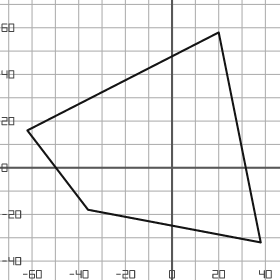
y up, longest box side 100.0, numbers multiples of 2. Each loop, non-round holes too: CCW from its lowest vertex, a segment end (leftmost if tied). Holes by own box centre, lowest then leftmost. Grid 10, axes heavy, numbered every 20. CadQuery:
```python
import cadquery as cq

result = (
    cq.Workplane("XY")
    .moveTo(38.0, -32.0)
    .lineTo(20.0, 58.0)
    .lineTo(-62.0, 16.0)
    .lineTo(-36.0, -18.0)
    .close()
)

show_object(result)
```